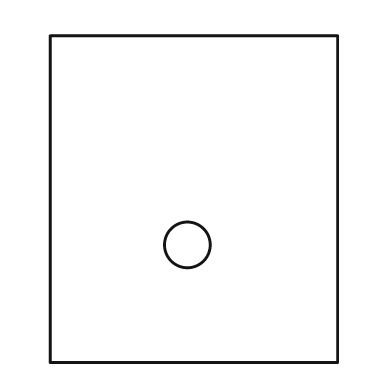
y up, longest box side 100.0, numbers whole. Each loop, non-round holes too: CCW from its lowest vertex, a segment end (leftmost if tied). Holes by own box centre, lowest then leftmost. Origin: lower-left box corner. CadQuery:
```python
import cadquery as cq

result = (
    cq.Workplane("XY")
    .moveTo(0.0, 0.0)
    .lineTo(88.0, 0.0)
    .lineTo(88.0, 100.0)
    .lineTo(0.0, 100.0)
    .close()
    .moveTo(42.0, 36.0)
    .circle(7.0)
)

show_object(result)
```